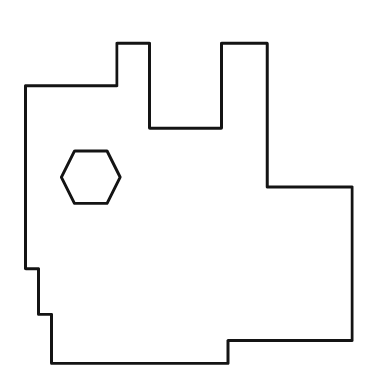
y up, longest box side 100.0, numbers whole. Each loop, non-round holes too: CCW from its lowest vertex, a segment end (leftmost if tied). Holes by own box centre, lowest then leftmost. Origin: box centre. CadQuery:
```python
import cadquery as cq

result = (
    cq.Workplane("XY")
    .moveTo(-42.0, -49.0)
    .lineTo(12.0, -49.0)
    .lineTo(12.0, -42.0)
    .lineTo(50.0, -42.0)
    .lineTo(50.0, 5.0)
    .lineTo(24.0, 5.0)
    .lineTo(24.0, 49.0)
    .lineTo(10.0, 49.0)
    .lineTo(10.0, 23.0)
    .lineTo(-12.0, 23.0)
    .lineTo(-12.0, 49.0)
    .lineTo(-22.0, 49.0)
    .lineTo(-22.0, 36.0)
    .lineTo(-50.0, 36.0)
    .lineTo(-50.0, -20.0)
    .lineTo(-46.0, -20.0)
    .lineTo(-46.0, -34.0)
    .lineTo(-42.0, -34.0)
    .close()
    .moveTo(-35.0, 0.0)
    .lineTo(-25.0, 0.0)
    .lineTo(-21.0, 8.0)
    .lineTo(-25.0, 16.0)
    .lineTo(-35.0, 16.0)
    .lineTo(-39.0, 8.0)
    .close()
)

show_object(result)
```